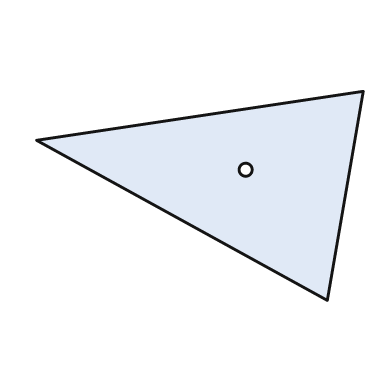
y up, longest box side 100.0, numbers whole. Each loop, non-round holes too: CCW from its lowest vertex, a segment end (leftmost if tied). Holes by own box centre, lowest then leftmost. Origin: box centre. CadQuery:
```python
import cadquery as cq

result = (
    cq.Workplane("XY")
    .moveTo(39.0, -32.0)
    .lineTo(50.0, 32.0)
    .lineTo(-50.0, 17.0)
    .close()
    .moveTo(14.0, 8.0)
    .circle(2.0)
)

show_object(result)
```